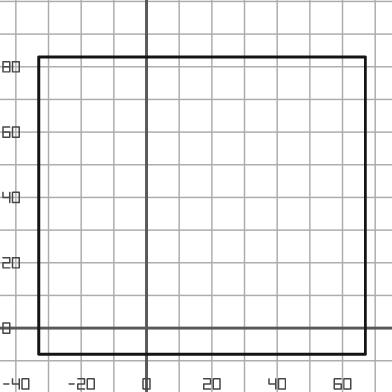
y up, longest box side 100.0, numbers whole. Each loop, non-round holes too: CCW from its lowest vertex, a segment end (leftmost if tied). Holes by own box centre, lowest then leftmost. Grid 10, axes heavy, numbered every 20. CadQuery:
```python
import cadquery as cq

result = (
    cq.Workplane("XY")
    .moveTo(-33.0, -8.0)
    .lineTo(67.0, -8.0)
    .lineTo(67.0, 83.0)
    .lineTo(-33.0, 83.0)
    .close()
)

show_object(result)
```